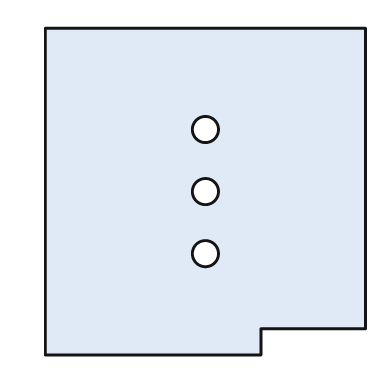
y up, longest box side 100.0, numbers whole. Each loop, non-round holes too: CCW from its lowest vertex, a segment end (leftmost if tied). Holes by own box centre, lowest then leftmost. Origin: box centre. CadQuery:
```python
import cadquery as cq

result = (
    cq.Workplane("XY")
    .moveTo(-49.0, -50.0)
    .lineTo(17.0, -50.0)
    .lineTo(17.0, -42.0)
    .lineTo(49.0, -42.0)
    .lineTo(49.0, 50.0)
    .lineTo(-49.0, 50.0)
    .close()
    .moveTo(0.0, -19.0)
    .circle(4.0)
    .moveTo(0.0, 0.0)
    .circle(4.0)
    .moveTo(0.0, 19.0)
    .circle(4.0)
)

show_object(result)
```